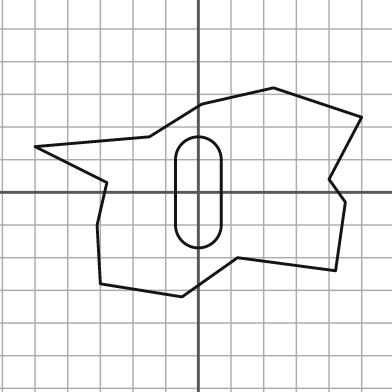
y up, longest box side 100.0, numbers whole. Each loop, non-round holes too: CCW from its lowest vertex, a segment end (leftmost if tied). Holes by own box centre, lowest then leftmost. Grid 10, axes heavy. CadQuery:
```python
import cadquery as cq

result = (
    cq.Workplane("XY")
    .moveTo(-5.0, -32.0)
    .lineTo(12.0, -20.0)
    .lineTo(42.0, -24.0)
    .lineTo(45.0, -3.0)
    .lineTo(40.0, 4.0)
    .lineTo(50.0, 23.0)
    .lineTo(23.0, 32.0)
    .lineTo(1.0, 27.0)
    .lineTo(-15.0, 17.0)
    .lineTo(-50.0, 14.0)
    .lineTo(-28.0, 3.0)
    .lineTo(-31.0, -10.0)
    .lineTo(-30.0, -28.0)
    .close()
    .moveTo(-7.0, -10.0)
    .threePointArc((0.0, -17.0), (7.0, -10.0))
    .lineTo(7.0, 10.0)
    .threePointArc((0.0, 17.0), (-7.0, 10.0))
    .close()
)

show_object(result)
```